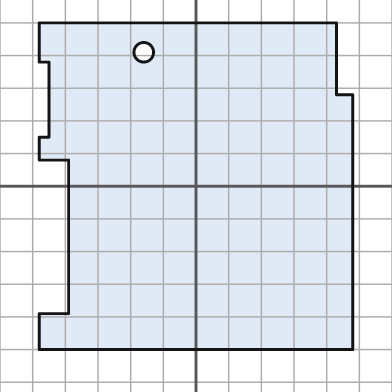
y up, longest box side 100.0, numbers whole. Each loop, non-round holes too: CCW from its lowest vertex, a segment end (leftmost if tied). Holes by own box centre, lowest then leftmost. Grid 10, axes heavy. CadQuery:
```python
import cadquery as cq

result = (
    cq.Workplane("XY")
    .moveTo(-48.0, -50.0)
    .lineTo(48.0, -50.0)
    .lineTo(48.0, 28.0)
    .lineTo(43.0, 28.0)
    .lineTo(43.0, 50.0)
    .lineTo(-48.0, 50.0)
    .lineTo(-48.0, 38.0)
    .lineTo(-45.0, 38.0)
    .lineTo(-45.0, 15.0)
    .lineTo(-48.0, 15.0)
    .lineTo(-48.0, 8.0)
    .lineTo(-39.0, 8.0)
    .lineTo(-39.0, -39.0)
    .lineTo(-48.0, -39.0)
    .close()
    .moveTo(-16.0, 41.0)
    .circle(3.0)
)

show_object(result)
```